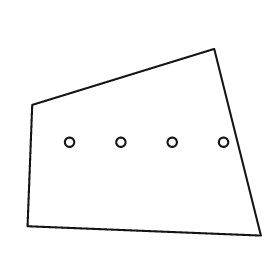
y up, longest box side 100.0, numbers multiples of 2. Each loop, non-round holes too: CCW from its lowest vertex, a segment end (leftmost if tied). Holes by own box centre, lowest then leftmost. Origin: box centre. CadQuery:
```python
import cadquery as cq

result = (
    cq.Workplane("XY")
    .moveTo(50.0, -40.0)
    .lineTo(30.0, 40.0)
    .lineTo(-48.0, 16.0)
    .lineTo(-50.0, -36.0)
    .close()
    .moveTo(-32.0, 0.0)
    .circle(2.0)
    .moveTo(-10.0, 0.0)
    .circle(2.0)
    .moveTo(12.0, 0.0)
    .circle(2.0)
    .moveTo(34.0, 0.0)
    .circle(2.0)
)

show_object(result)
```